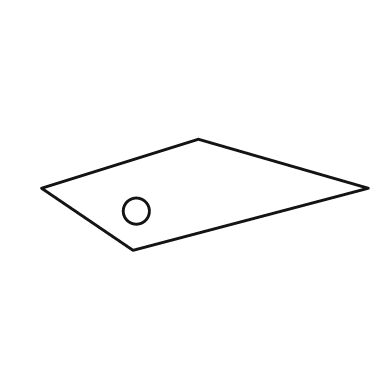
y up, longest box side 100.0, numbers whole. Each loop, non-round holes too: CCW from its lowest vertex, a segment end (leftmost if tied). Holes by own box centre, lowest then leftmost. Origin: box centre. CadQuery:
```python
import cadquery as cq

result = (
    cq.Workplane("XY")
    .moveTo(-22.0, -17.0)
    .lineTo(50.0, 2.0)
    .lineTo(-2.0, 17.0)
    .lineTo(-50.0, 2.0)
    .close()
    .moveTo(-21.0, -5.0)
    .circle(4.0)
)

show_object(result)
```